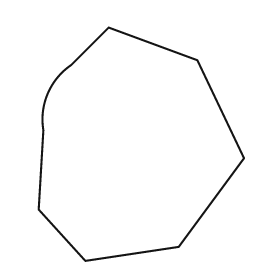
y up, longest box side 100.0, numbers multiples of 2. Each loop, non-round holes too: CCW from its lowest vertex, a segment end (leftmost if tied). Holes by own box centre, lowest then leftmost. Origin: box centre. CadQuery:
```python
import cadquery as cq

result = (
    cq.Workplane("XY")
    .moveTo(-24.0, -50.0)
    .lineTo(16.0, -44.0)
    .lineTo(44.0, -6.0)
    .lineTo(24.0, 36.0)
    .lineTo(-14.0, 50.0)
    .lineTo(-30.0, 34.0)
    .threePointArc((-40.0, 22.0), (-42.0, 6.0))
    .lineTo(-44.0, -28.0)
    .close()
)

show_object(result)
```